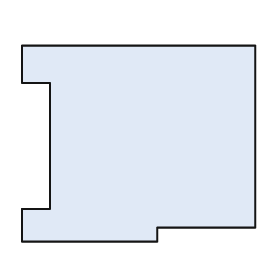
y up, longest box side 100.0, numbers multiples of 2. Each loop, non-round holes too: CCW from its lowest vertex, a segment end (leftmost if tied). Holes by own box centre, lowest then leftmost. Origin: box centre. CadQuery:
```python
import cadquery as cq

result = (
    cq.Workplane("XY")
    .moveTo(-50.0, -42.0)
    .lineTo(8.0, -42.0)
    .lineTo(8.0, -36.0)
    .lineTo(50.0, -36.0)
    .lineTo(50.0, 42.0)
    .lineTo(-50.0, 42.0)
    .lineTo(-50.0, 26.0)
    .lineTo(-38.0, 26.0)
    .lineTo(-38.0, -28.0)
    .lineTo(-50.0, -28.0)
    .close()
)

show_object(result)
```